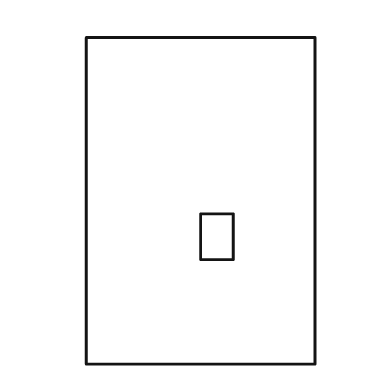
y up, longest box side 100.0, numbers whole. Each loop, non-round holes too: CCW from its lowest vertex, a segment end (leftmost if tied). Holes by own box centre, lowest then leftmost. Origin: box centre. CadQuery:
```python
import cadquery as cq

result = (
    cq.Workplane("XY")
    .moveTo(-35.0, -50.0)
    .lineTo(35.0, -50.0)
    .lineTo(35.0, 50.0)
    .lineTo(-35.0, 50.0)
    .close()
    .moveTo(0.0, -18.0)
    .lineTo(10.0, -18.0)
    .lineTo(10.0, -4.0)
    .lineTo(0.0, -4.0)
    .close()
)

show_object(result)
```